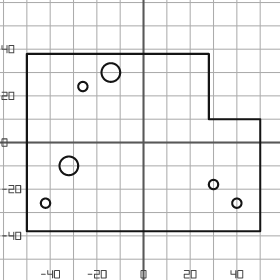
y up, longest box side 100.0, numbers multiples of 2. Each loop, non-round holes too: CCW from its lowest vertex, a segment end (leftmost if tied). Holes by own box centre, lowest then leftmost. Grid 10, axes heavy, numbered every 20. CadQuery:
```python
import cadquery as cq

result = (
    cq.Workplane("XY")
    .moveTo(-50.0, -38.0)
    .lineTo(50.0, -38.0)
    .lineTo(50.0, 10.0)
    .lineTo(28.0, 10.0)
    .lineTo(28.0, 38.0)
    .lineTo(-50.0, 38.0)
    .close()
    .moveTo(-42.0, -26.0)
    .circle(2.0)
    .moveTo(40.0, -26.0)
    .circle(2.0)
    .moveTo(30.0, -18.0)
    .circle(2.0)
    .moveTo(-32.0, -10.0)
    .circle(4.0)
    .moveTo(-26.0, 24.0)
    .circle(2.0)
    .moveTo(-14.0, 30.0)
    .circle(4.0)
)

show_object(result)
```